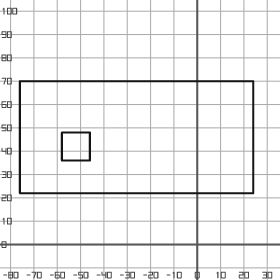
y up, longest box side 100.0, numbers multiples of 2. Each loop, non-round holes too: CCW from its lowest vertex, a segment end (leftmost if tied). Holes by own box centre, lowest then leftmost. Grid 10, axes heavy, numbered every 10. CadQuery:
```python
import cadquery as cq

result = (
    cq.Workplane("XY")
    .moveTo(-76.0, 22.0)
    .lineTo(24.0, 22.0)
    .lineTo(24.0, 70.0)
    .lineTo(-76.0, 70.0)
    .close()
    .moveTo(-58.0, 36.0)
    .lineTo(-46.0, 36.0)
    .lineTo(-46.0, 48.0)
    .lineTo(-58.0, 48.0)
    .close()
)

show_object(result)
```